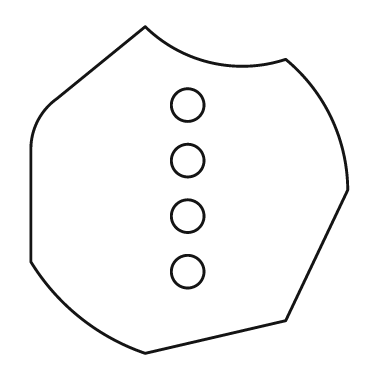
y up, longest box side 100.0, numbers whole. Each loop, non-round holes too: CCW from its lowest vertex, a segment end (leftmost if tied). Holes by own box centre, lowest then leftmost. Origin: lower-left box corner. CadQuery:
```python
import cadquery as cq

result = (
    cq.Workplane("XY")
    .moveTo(35.0, 0.0)
    .lineTo(78.0, 10.0)
    .lineTo(97.0, 50.0)
    .threePointArc((92.0, 72.0), (78.0, 90.0))
    .threePointArc((55.0, 89.0), (35.0, 100.0))
    .lineTo(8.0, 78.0)
    .threePointArc((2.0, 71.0), (0.0, 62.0))
    .lineTo(0.0, 28.0)
    .threePointArc((15.0, 11.0), (35.0, 0.0))
    .close()
    .moveTo(48.0, 25.0)
    .circle(5.0)
    .moveTo(48.0, 42.0)
    .circle(5.0)
    .moveTo(48.0, 59.0)
    .circle(5.0)
    .moveTo(48.0, 76.0)
    .circle(5.0)
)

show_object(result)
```